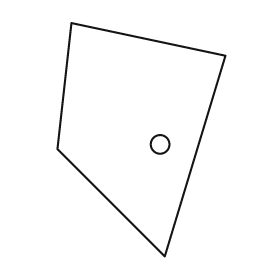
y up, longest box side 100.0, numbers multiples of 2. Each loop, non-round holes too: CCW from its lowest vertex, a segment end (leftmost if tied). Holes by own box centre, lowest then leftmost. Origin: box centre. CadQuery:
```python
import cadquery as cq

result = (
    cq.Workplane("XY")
    .moveTo(10.0, -50.0)
    .lineTo(36.0, 36.0)
    .lineTo(-30.0, 50.0)
    .lineTo(-36.0, -4.0)
    .close()
    .moveTo(8.0, -2.0)
    .circle(4.0)
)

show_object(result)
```